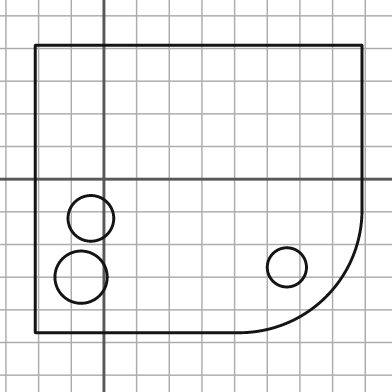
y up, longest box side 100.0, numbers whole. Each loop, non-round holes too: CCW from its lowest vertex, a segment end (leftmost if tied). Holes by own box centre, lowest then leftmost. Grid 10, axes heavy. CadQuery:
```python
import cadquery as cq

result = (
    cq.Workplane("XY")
    .moveTo(-21.0, -47.0)
    .lineTo(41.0, -47.0)
    .threePointArc((68.0, -36.0), (79.0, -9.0))
    .lineTo(79.0, 41.0)
    .lineTo(-21.0, 41.0)
    .close()
    .moveTo(-7.0, -30.0)
    .circle(8.0)
    .moveTo(56.0, -27.0)
    .circle(6.0)
    .moveTo(-4.0, -12.0)
    .circle(7.0)
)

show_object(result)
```